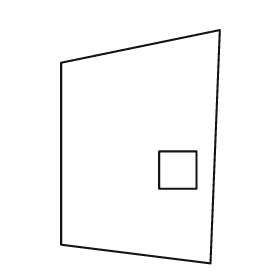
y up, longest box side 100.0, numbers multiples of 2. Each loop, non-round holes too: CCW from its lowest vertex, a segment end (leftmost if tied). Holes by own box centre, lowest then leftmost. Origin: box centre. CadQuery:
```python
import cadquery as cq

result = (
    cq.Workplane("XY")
    .moveTo(30.0, -50.0)
    .lineTo(34.0, 50.0)
    .lineTo(-34.0, 36.0)
    .lineTo(-34.0, -42.0)
    .close()
    .moveTo(8.0, -18.0)
    .lineTo(24.0, -18.0)
    .lineTo(24.0, -2.0)
    .lineTo(8.0, -2.0)
    .close()
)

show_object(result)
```